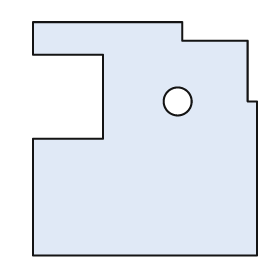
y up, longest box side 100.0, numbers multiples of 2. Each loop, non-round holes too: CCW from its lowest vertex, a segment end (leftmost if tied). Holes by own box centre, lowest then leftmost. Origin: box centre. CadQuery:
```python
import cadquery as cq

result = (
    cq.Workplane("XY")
    .moveTo(-48.0, -50.0)
    .lineTo(48.0, -50.0)
    .lineTo(48.0, 16.0)
    .lineTo(44.0, 16.0)
    .lineTo(44.0, 42.0)
    .lineTo(16.0, 42.0)
    .lineTo(16.0, 50.0)
    .lineTo(-48.0, 50.0)
    .lineTo(-48.0, 36.0)
    .lineTo(-18.0, 36.0)
    .lineTo(-18.0, 0.0)
    .lineTo(-48.0, 0.0)
    .close()
    .moveTo(14.0, 16.0)
    .circle(6.0)
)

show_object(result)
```